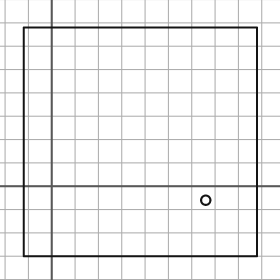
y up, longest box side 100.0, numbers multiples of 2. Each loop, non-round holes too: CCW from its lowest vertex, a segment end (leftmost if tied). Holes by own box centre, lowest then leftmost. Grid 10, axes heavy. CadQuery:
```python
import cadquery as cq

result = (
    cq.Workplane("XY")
    .moveTo(-12.0, -30.0)
    .lineTo(88.0, -30.0)
    .lineTo(88.0, 68.0)
    .lineTo(-12.0, 68.0)
    .close()
    .moveTo(66.0, -6.0)
    .circle(2.0)
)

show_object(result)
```